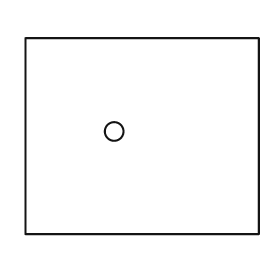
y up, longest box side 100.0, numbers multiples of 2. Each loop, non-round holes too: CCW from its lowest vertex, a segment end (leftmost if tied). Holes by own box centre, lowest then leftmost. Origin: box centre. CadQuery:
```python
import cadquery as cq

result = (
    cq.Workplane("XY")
    .moveTo(-50.0, -42.0)
    .lineTo(50.0, -42.0)
    .lineTo(50.0, 42.0)
    .lineTo(-50.0, 42.0)
    .close()
    .moveTo(-12.0, 2.0)
    .circle(4.0)
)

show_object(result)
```